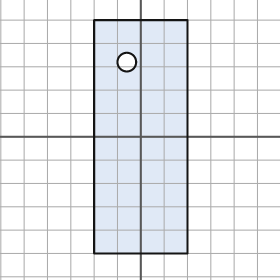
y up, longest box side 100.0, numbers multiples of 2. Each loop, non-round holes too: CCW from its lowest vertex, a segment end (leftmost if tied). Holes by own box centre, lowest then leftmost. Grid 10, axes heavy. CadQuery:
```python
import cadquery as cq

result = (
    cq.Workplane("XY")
    .moveTo(-20.0, -50.0)
    .lineTo(20.0, -50.0)
    .lineTo(20.0, 50.0)
    .lineTo(-20.0, 50.0)
    .close()
    .moveTo(-6.0, 32.0)
    .circle(4.0)
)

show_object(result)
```